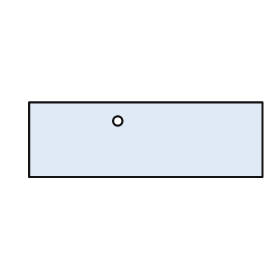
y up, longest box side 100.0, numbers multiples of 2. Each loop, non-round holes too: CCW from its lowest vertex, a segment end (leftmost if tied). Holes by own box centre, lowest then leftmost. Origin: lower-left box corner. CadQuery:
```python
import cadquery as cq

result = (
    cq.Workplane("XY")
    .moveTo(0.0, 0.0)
    .lineTo(100.0, 0.0)
    .lineTo(100.0, 32.0)
    .lineTo(0.0, 32.0)
    .close()
    .moveTo(38.0, 24.0)
    .circle(2.0)
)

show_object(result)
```